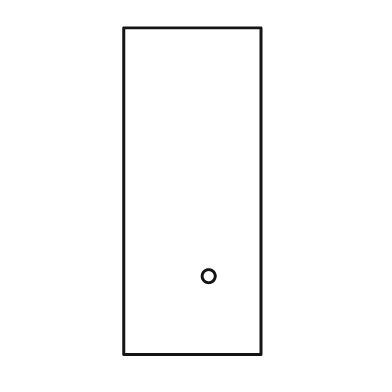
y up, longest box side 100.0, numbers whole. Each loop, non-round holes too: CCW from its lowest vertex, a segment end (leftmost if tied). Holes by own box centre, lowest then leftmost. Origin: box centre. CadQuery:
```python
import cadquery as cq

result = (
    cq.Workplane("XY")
    .moveTo(-21.0, -50.0)
    .lineTo(21.0, -50.0)
    .lineTo(21.0, 50.0)
    .lineTo(-21.0, 50.0)
    .close()
    .moveTo(5.0, -26.0)
    .circle(2.0)
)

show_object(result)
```